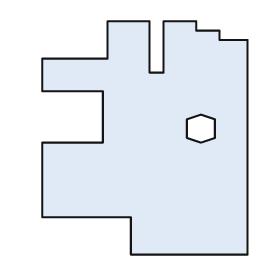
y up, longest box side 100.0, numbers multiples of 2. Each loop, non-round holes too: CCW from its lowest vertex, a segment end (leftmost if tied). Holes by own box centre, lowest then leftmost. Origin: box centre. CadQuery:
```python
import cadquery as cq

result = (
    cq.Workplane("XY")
    .moveTo(-6.0, -50.0)
    .lineTo(44.0, -50.0)
    .lineTo(44.0, 42.0)
    .lineTo(32.0, 42.0)
    .lineTo(32.0, 46.0)
    .lineTo(22.0, 46.0)
    .lineTo(22.0, 50.0)
    .lineTo(8.0, 50.0)
    .lineTo(8.0, 28.0)
    .lineTo(2.0, 28.0)
    .lineTo(2.0, 50.0)
    .lineTo(-16.0, 50.0)
    .lineTo(-16.0, 34.0)
    .lineTo(-44.0, 34.0)
    .lineTo(-44.0, 20.0)
    .lineTo(-18.0, 20.0)
    .lineTo(-18.0, -2.0)
    .lineTo(-44.0, -2.0)
    .lineTo(-44.0, -34.0)
    .lineTo(-6.0, -34.0)
    .close()
    .moveTo(24.0, -2.0)
    .lineTo(30.0, 0.0)
    .lineTo(30.0, 8.0)
    .lineTo(24.0, 10.0)
    .lineTo(18.0, 8.0)
    .lineTo(18.0, 0.0)
    .close()
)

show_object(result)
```